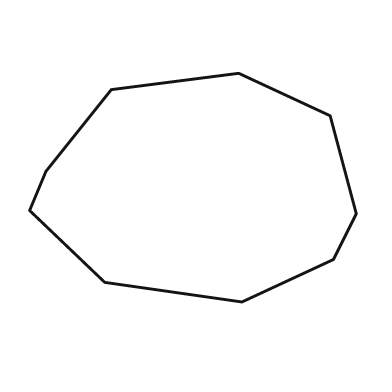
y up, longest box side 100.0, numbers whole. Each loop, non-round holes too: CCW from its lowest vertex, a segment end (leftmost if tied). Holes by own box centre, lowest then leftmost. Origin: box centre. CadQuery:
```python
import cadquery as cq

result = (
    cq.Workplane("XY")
    .moveTo(15.0, -35.0)
    .lineTo(43.0, -22.0)
    .lineTo(50.0, -8.0)
    .lineTo(42.0, 22.0)
    .lineTo(14.0, 35.0)
    .lineTo(-25.0, 30.0)
    .lineTo(-45.0, 5.0)
    .lineTo(-50.0, -7.0)
    .lineTo(-27.0, -29.0)
    .close()
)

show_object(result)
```